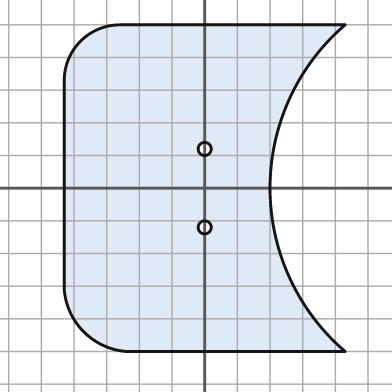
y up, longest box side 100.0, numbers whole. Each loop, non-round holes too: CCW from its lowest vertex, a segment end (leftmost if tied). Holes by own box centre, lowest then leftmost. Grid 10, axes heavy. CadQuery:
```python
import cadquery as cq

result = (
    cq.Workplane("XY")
    .moveTo(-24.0, -50.0)
    .lineTo(43.0, -50.0)
    .threePointArc((20.0, 0.0), (43.0, 50.0))
    .lineTo(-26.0, 50.0)
    .threePointArc((-38.0, 45.0), (-43.0, 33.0))
    .lineTo(-43.0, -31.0)
    .threePointArc((-37.0, -44.0), (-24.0, -50.0))
    .close()
    .moveTo(0.0, -12.0)
    .circle(2.0)
    .moveTo(0.0, 12.0)
    .circle(2.0)
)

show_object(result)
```